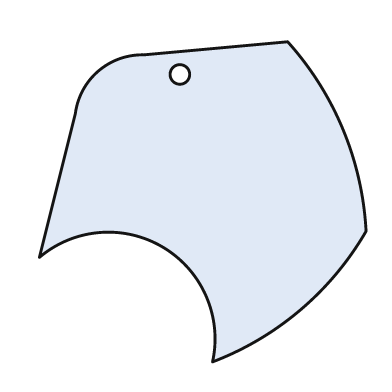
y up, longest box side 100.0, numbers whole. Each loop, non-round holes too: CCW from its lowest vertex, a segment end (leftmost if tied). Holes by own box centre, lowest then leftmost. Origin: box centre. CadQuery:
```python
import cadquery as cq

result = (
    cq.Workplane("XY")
    .moveTo(3.0, -49.0)
    .threePointArc((30.0, -33.0), (50.0, -9.0))
    .threePointArc((43.0, 22.0), (26.0, 49.0))
    .lineTo(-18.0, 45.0)
    .threePointArc((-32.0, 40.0), (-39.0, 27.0))
    .lineTo(-50.0, -17.0)
    .threePointArc((-12.0, -14.0), (3.0, -49.0))
    .close()
    .moveTo(-7.0, 39.0)
    .circle(3.0)
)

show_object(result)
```